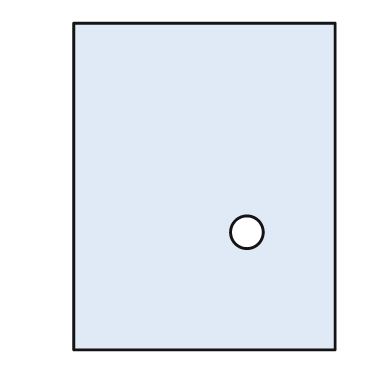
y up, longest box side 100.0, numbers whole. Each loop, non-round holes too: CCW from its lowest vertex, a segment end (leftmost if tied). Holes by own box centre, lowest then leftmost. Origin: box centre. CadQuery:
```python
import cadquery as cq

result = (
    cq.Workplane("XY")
    .moveTo(-40.0, -50.0)
    .lineTo(40.0, -50.0)
    .lineTo(40.0, 50.0)
    .lineTo(-40.0, 50.0)
    .close()
    .moveTo(13.0, -14.0)
    .circle(5.0)
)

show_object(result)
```